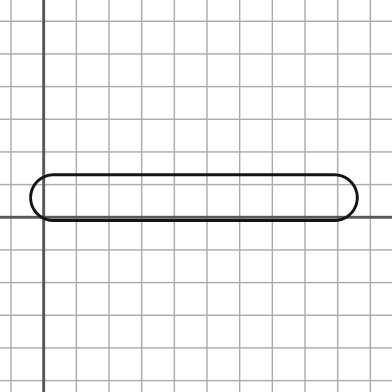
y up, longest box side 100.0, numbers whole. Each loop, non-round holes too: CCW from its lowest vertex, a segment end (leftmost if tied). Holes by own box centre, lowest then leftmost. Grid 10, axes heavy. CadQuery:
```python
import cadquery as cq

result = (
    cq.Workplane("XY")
    .moveTo(3.0, -1.0)
    .lineTo(89.0, -1.0)
    .threePointArc((96.0, 6.0), (89.0, 13.0))
    .lineTo(3.0, 13.0)
    .threePointArc((-4.0, 6.0), (3.0, -1.0))
    .close()
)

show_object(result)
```